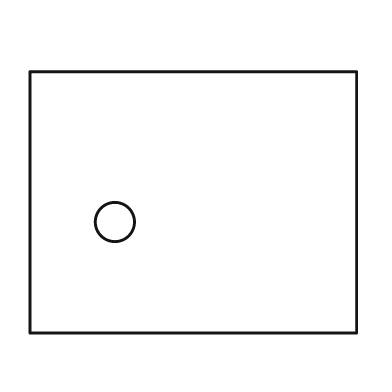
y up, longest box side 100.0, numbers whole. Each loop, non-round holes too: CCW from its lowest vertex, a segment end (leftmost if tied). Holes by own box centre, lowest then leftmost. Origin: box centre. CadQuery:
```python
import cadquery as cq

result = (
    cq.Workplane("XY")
    .moveTo(-50.0, -40.0)
    .lineTo(50.0, -40.0)
    .lineTo(50.0, 40.0)
    .lineTo(-50.0, 40.0)
    .close()
    .moveTo(-24.0, -6.0)
    .circle(6.0)
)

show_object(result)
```